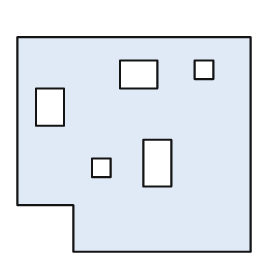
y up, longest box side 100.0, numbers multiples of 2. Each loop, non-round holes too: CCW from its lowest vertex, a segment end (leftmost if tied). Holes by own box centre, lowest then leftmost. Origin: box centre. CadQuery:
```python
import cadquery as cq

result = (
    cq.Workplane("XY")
    .moveTo(-26.0, -46.0)
    .lineTo(50.0, -46.0)
    .lineTo(50.0, 46.0)
    .lineTo(-50.0, 46.0)
    .lineTo(-50.0, -26.0)
    .lineTo(-26.0, -26.0)
    .close()
    .moveTo(-18.0, -14.0)
    .lineTo(-10.0, -14.0)
    .lineTo(-10.0, -6.0)
    .lineTo(-18.0, -6.0)
    .close()
    .moveTo(4.0, -18.0)
    .lineTo(16.0, -18.0)
    .lineTo(16.0, 2.0)
    .lineTo(4.0, 2.0)
    .close()
    .moveTo(-42.0, 8.0)
    .lineTo(-30.0, 8.0)
    .lineTo(-30.0, 24.0)
    .lineTo(-42.0, 24.0)
    .close()
    .moveTo(-6.0, 24.0)
    .lineTo(10.0, 24.0)
    .lineTo(10.0, 36.0)
    .lineTo(-6.0, 36.0)
    .close()
    .moveTo(26.0, 28.0)
    .lineTo(34.0, 28.0)
    .lineTo(34.0, 36.0)
    .lineTo(26.0, 36.0)
    .close()
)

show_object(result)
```